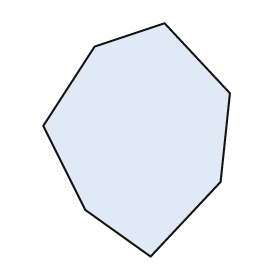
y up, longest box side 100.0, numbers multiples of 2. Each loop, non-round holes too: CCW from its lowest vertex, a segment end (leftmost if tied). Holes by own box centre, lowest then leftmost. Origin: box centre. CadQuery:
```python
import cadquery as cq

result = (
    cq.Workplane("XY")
    .moveTo(6.0, -50.0)
    .lineTo(36.0, -18.0)
    .lineTo(40.0, 20.0)
    .lineTo(12.0, 50.0)
    .lineTo(-18.0, 40.0)
    .lineTo(-40.0, 6.0)
    .lineTo(-22.0, -30.0)
    .close()
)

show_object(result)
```